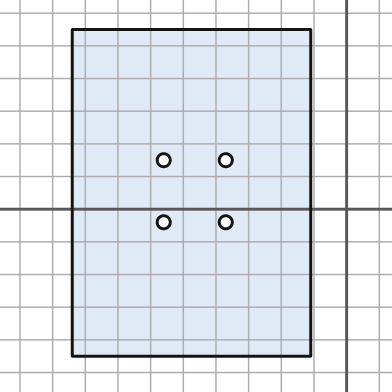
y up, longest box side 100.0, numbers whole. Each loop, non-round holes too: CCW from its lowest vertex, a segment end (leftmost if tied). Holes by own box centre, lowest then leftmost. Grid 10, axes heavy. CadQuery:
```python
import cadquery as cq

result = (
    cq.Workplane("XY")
    .moveTo(-84.0, -45.0)
    .lineTo(-11.0, -45.0)
    .lineTo(-11.0, 55.0)
    .lineTo(-84.0, 55.0)
    .close()
    .moveTo(-56.0, -4.0)
    .circle(2.0)
    .moveTo(-37.0, -4.0)
    .circle(2.0)
    .moveTo(-56.0, 15.0)
    .circle(2.0)
    .moveTo(-37.0, 15.0)
    .circle(2.0)
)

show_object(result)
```